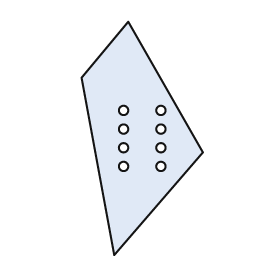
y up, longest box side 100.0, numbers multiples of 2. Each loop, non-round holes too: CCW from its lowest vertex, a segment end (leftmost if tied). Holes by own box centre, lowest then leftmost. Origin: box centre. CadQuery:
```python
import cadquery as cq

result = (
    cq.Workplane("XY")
    .moveTo(-12.0, -50.0)
    .lineTo(26.0, -6.0)
    .lineTo(-6.0, 50.0)
    .lineTo(-26.0, 26.0)
    .close()
    .moveTo(-8.0, -12.0)
    .circle(2.0)
    .moveTo(8.0, -12.0)
    .circle(2.0)
    .moveTo(-8.0, -4.0)
    .circle(2.0)
    .moveTo(8.0, -4.0)
    .circle(2.0)
    .moveTo(-8.0, 4.0)
    .circle(2.0)
    .moveTo(8.0, 4.0)
    .circle(2.0)
    .moveTo(-8.0, 12.0)
    .circle(2.0)
    .moveTo(8.0, 12.0)
    .circle(2.0)
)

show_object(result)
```